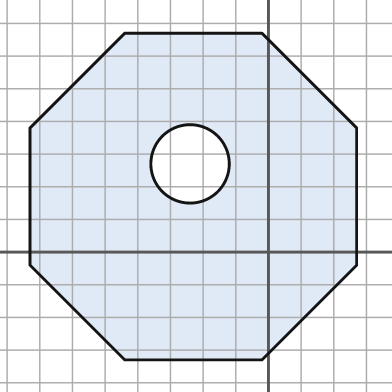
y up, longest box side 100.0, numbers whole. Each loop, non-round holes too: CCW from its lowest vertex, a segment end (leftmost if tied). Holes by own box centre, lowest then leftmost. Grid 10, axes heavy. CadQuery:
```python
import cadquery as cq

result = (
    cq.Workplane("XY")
    .moveTo(-44.0, -33.0)
    .lineTo(-2.0, -33.0)
    .lineTo(27.0, -4.0)
    .lineTo(27.0, 38.0)
    .lineTo(-2.0, 67.0)
    .lineTo(-44.0, 67.0)
    .lineTo(-73.0, 38.0)
    .lineTo(-73.0, -4.0)
    .close()
    .moveTo(-24.0, 27.0)
    .circle(12.0)
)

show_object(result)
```